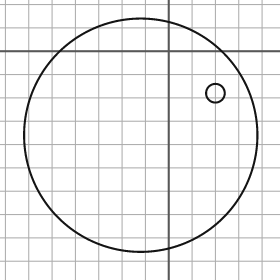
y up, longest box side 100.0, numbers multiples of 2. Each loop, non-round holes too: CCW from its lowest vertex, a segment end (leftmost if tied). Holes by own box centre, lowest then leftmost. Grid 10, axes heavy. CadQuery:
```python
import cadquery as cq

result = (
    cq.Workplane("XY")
    .moveTo(-12.0, -36.0)
    .circle(50.0)
    .moveTo(20.0, -18.0)
    .circle(4.0)
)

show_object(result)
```